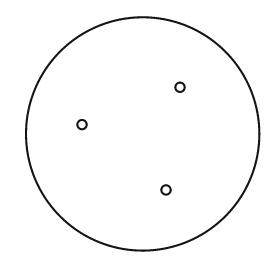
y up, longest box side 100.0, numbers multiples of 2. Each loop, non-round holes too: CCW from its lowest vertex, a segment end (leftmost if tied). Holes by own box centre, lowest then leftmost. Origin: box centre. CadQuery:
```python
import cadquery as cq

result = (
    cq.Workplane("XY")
    .moveTo(0.0, 0.0)
    .circle(50.0)
    .moveTo(10.0, -24.0)
    .circle(2.0)
    .moveTo(-26.0, 4.0)
    .circle(2.0)
    .moveTo(16.0, 20.0)
    .circle(2.0)
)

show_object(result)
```